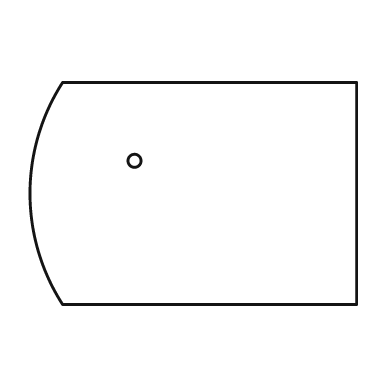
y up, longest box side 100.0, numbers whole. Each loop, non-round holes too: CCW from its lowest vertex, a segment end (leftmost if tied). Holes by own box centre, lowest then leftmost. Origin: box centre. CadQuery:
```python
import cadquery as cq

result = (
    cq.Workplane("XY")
    .moveTo(-40.0, -34.0)
    .lineTo(50.0, -34.0)
    .lineTo(50.0, 34.0)
    .lineTo(-40.0, 34.0)
    .threePointArc((-50.0, 0.0), (-40.0, -34.0))
    .close()
    .moveTo(-18.0, 10.0)
    .circle(2.0)
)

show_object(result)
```